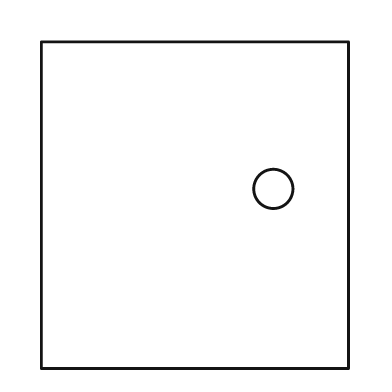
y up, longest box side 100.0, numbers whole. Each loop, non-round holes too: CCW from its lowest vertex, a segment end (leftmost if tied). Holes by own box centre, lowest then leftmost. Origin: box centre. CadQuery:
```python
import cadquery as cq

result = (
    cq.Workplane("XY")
    .moveTo(-47.0, -50.0)
    .lineTo(47.0, -50.0)
    .lineTo(47.0, 50.0)
    .lineTo(-47.0, 50.0)
    .close()
    .moveTo(24.0, 5.0)
    .circle(6.0)
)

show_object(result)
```